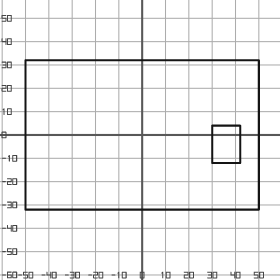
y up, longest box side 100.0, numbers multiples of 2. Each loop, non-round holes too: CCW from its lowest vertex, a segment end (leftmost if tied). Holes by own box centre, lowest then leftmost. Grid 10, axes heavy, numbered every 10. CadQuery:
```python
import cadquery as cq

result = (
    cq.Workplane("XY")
    .moveTo(-50.0, -32.0)
    .lineTo(50.0, -32.0)
    .lineTo(50.0, 32.0)
    .lineTo(-50.0, 32.0)
    .close()
    .moveTo(30.0, -12.0)
    .lineTo(42.0, -12.0)
    .lineTo(42.0, 4.0)
    .lineTo(30.0, 4.0)
    .close()
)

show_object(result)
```